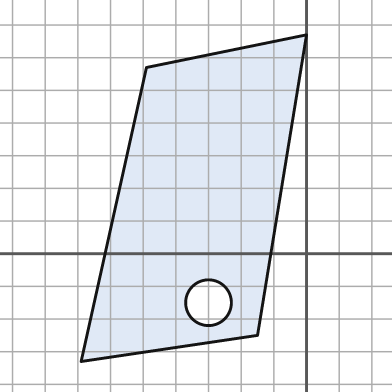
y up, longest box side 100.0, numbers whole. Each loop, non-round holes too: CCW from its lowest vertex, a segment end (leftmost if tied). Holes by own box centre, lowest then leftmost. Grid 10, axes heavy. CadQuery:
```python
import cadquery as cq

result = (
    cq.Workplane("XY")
    .moveTo(-69.0, -33.0)
    .lineTo(-15.0, -25.0)
    .lineTo(0.0, 67.0)
    .lineTo(-49.0, 57.0)
    .close()
    .moveTo(-30.0, -15.0)
    .circle(7.0)
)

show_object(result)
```